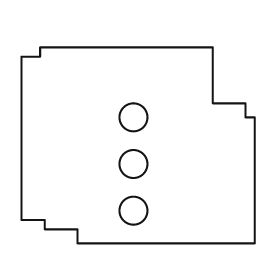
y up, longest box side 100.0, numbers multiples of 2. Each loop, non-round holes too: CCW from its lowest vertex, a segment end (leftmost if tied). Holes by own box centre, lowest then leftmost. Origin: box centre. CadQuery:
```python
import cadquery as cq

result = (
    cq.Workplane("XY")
    .moveTo(-26.0, -42.0)
    .lineTo(50.0, -42.0)
    .lineTo(50.0, 12.0)
    .lineTo(46.0, 12.0)
    .lineTo(46.0, 18.0)
    .lineTo(32.0, 18.0)
    .lineTo(32.0, 42.0)
    .lineTo(-42.0, 42.0)
    .lineTo(-42.0, 38.0)
    .lineTo(-50.0, 38.0)
    .lineTo(-50.0, -32.0)
    .lineTo(-40.0, -32.0)
    .lineTo(-40.0, -36.0)
    .lineTo(-26.0, -36.0)
    .close()
    .moveTo(-2.0, -28.0)
    .circle(6.0)
    .moveTo(-2.0, -8.0)
    .circle(6.0)
    .moveTo(-2.0, 12.0)
    .circle(6.0)
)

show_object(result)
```